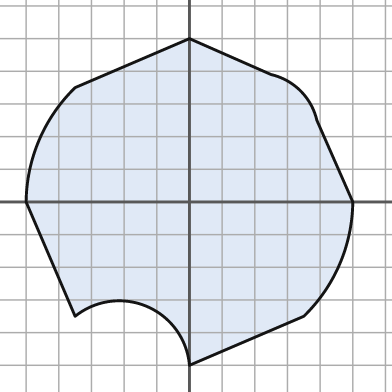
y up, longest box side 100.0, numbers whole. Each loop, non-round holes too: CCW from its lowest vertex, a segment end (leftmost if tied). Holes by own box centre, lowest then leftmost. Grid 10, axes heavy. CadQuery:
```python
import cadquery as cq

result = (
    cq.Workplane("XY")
    .moveTo(0.0, -50.0)
    .lineTo(35.0, -35.0)
    .threePointArc((46.0, -19.0), (50.0, 0.0))
    .lineTo(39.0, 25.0)
    .threePointArc((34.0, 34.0), (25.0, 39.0))
    .lineTo(0.0, 50.0)
    .lineTo(-35.0, 35.0)
    .threePointArc((-46.0, 19.0), (-50.0, 0.0))
    .lineTo(-35.0, -35.0)
    .threePointArc((-13.0, -32.0), (0.0, -50.0))
    .close()
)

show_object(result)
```